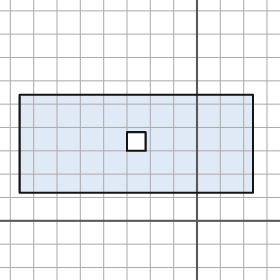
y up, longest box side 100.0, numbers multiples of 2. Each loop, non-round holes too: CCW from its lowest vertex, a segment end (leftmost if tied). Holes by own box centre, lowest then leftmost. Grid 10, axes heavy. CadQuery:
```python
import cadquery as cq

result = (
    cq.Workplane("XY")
    .moveTo(-76.0, 12.0)
    .lineTo(24.0, 12.0)
    .lineTo(24.0, 54.0)
    .lineTo(-76.0, 54.0)
    .close()
    .moveTo(-30.0, 30.0)
    .lineTo(-22.0, 30.0)
    .lineTo(-22.0, 38.0)
    .lineTo(-30.0, 38.0)
    .close()
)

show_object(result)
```